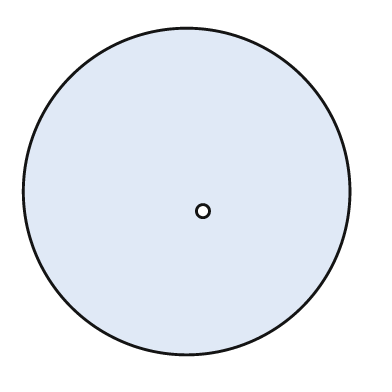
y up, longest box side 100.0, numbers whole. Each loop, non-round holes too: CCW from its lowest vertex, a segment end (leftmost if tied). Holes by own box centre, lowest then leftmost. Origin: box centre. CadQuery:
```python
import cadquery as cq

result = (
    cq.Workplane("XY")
    .moveTo(0.0, 0.0)
    .circle(50.0)
    .moveTo(5.0, -6.0)
    .circle(2.0)
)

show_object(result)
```